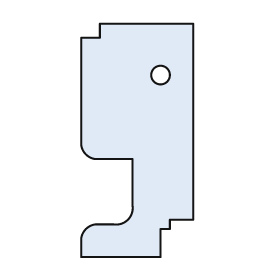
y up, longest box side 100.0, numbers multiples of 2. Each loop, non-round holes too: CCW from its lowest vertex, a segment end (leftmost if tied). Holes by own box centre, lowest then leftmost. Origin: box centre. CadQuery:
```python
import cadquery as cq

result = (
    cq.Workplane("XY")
    .moveTo(-24.0, -50.0)
    .lineTo(10.0, -50.0)
    .lineTo(10.0, -38.0)
    .lineTo(14.0, -38.0)
    .lineTo(14.0, -34.0)
    .lineTo(24.0, -34.0)
    .lineTo(24.0, 50.0)
    .lineTo(-16.0, 50.0)
    .lineTo(-16.0, 44.0)
    .lineTo(-24.0, 44.0)
    .lineTo(-24.0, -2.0)
    .threePointArc((-22.0, -6.0), (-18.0, -8.0))
    .lineTo(-2.0, -8.0)
    .lineTo(-2.0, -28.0)
    .threePointArc((-4.0, -34.0), (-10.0, -36.0))
    .lineTo(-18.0, -36.0)
    .threePointArc((-22.0, -38.0), (-24.0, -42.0))
    .close()
    .moveTo(10.0, 28.0)
    .circle(4.0)
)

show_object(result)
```